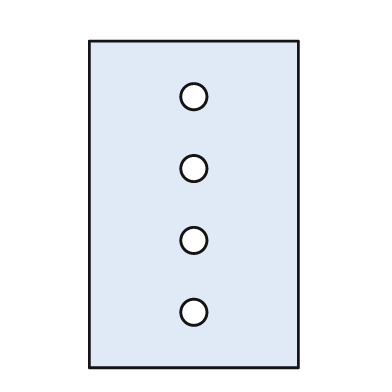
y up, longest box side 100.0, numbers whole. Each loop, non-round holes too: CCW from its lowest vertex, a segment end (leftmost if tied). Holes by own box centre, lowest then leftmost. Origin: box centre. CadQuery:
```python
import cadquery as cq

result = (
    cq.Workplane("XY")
    .moveTo(-32.0, -50.0)
    .lineTo(32.0, -50.0)
    .lineTo(32.0, 50.0)
    .lineTo(-32.0, 50.0)
    .close()
    .moveTo(0.0, -33.0)
    .circle(4.0)
    .moveTo(0.0, -11.0)
    .circle(4.0)
    .moveTo(0.0, 11.0)
    .circle(4.0)
    .moveTo(0.0, 33.0)
    .circle(4.0)
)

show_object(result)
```